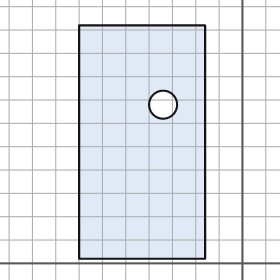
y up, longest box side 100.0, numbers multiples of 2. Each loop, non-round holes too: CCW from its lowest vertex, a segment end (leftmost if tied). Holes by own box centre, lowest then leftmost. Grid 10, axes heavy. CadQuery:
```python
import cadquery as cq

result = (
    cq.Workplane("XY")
    .moveTo(-70.0, 2.0)
    .lineTo(-16.0, 2.0)
    .lineTo(-16.0, 102.0)
    .lineTo(-70.0, 102.0)
    .close()
    .moveTo(-34.0, 68.0)
    .circle(6.0)
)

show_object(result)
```